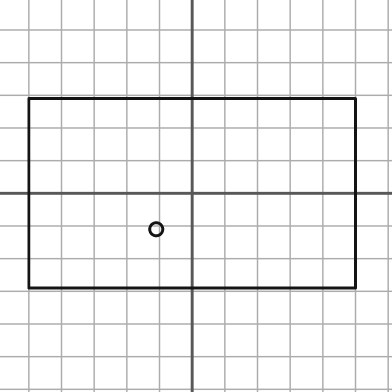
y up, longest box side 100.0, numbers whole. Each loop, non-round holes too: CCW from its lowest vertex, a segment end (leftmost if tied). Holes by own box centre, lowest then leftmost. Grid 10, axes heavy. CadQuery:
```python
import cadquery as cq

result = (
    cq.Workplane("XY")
    .moveTo(-50.0, -29.0)
    .lineTo(50.0, -29.0)
    .lineTo(50.0, 29.0)
    .lineTo(-50.0, 29.0)
    .close()
    .moveTo(-11.0, -11.0)
    .circle(2.0)
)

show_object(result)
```